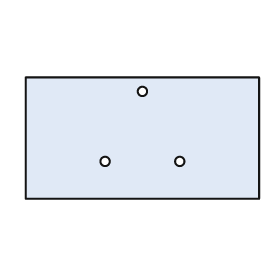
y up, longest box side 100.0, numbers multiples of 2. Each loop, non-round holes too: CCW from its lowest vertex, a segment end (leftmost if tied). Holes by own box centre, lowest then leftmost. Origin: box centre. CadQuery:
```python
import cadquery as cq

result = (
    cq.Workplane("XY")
    .moveTo(-50.0, -26.0)
    .lineTo(50.0, -26.0)
    .lineTo(50.0, 26.0)
    .lineTo(-50.0, 26.0)
    .close()
    .moveTo(-16.0, -10.0)
    .circle(2.0)
    .moveTo(16.0, -10.0)
    .circle(2.0)
    .moveTo(0.0, 20.0)
    .circle(2.0)
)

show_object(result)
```